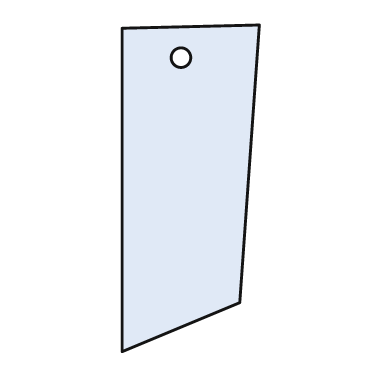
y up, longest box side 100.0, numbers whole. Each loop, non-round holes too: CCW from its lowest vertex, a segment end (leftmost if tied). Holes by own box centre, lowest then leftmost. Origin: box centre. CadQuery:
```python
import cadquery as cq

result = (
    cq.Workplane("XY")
    .moveTo(-21.0, -50.0)
    .lineTo(15.0, -35.0)
    .lineTo(21.0, 50.0)
    .lineTo(-21.0, 49.0)
    .close()
    .moveTo(-3.0, 40.0)
    .circle(3.0)
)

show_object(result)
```